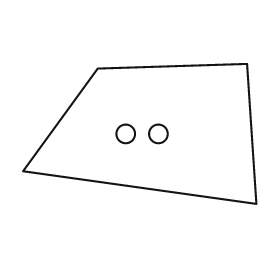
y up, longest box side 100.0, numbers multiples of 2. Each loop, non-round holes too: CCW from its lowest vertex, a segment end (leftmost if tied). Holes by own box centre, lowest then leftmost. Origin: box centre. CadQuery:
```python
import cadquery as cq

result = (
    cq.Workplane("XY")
    .moveTo(50.0, -30.0)
    .lineTo(46.0, 30.0)
    .lineTo(-18.0, 28.0)
    .lineTo(-50.0, -16.0)
    .close()
    .moveTo(-6.0, 0.0)
    .circle(4.0)
    .moveTo(8.0, 0.0)
    .circle(4.0)
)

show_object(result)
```